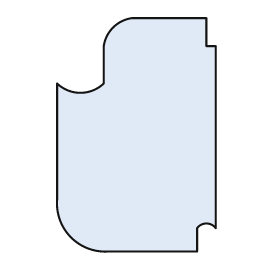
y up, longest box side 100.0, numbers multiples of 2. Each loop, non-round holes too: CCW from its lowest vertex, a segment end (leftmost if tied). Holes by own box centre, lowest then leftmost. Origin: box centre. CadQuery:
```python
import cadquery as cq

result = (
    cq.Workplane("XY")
    .moveTo(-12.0, -50.0)
    .lineTo(26.0, -50.0)
    .lineTo(26.0, -40.0)
    .threePointArc((30.0, -38.0), (34.0, -40.0))
    .lineTo(34.0, 38.0)
    .lineTo(30.0, 38.0)
    .lineTo(30.0, 50.0)
    .lineTo(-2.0, 50.0)
    .threePointArc((-10.0, 46.0), (-14.0, 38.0))
    .lineTo(-14.0, 22.0)
    .threePointArc((-24.0, 18.0), (-34.0, 22.0))
    .lineTo(-34.0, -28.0)
    .threePointArc((-28.0, -44.0), (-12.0, -50.0))
    .close()
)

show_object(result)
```